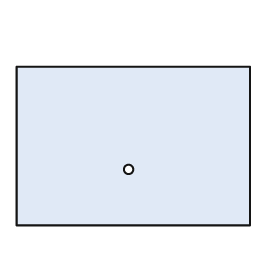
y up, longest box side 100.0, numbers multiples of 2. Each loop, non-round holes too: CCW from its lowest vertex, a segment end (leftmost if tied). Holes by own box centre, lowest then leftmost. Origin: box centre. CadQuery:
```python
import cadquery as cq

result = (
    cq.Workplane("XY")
    .moveTo(-50.0, -34.0)
    .lineTo(50.0, -34.0)
    .lineTo(50.0, 34.0)
    .lineTo(-50.0, 34.0)
    .close()
    .moveTo(-2.0, -10.0)
    .circle(2.0)
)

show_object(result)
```